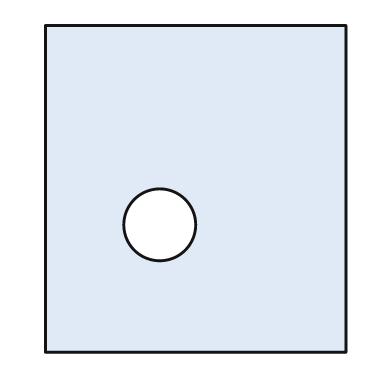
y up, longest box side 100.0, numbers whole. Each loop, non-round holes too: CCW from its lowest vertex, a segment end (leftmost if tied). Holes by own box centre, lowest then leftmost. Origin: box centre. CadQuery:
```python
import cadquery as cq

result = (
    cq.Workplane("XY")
    .moveTo(-46.0, -50.0)
    .lineTo(46.0, -50.0)
    .lineTo(46.0, 50.0)
    .lineTo(-46.0, 50.0)
    .close()
    .moveTo(-11.0, -11.0)
    .circle(11.0)
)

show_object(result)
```